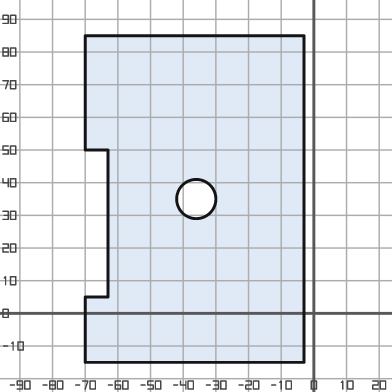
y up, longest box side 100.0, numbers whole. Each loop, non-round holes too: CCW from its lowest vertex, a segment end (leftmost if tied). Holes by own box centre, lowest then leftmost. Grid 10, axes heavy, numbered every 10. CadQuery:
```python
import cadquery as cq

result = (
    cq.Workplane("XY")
    .moveTo(-70.0, -15.0)
    .lineTo(-3.0, -15.0)
    .lineTo(-3.0, 85.0)
    .lineTo(-70.0, 85.0)
    .lineTo(-70.0, 50.0)
    .lineTo(-63.0, 50.0)
    .lineTo(-63.0, 5.0)
    .lineTo(-70.0, 5.0)
    .close()
    .moveTo(-36.0, 35.0)
    .circle(6.0)
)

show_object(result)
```